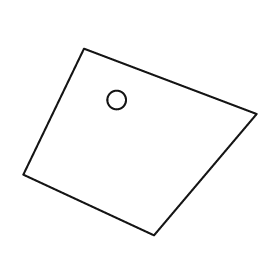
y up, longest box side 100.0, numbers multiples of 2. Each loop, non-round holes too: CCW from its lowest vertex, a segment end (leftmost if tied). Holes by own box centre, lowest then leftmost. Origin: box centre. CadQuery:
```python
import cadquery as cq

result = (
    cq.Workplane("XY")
    .moveTo(6.0, -40.0)
    .lineTo(50.0, 12.0)
    .lineTo(-24.0, 40.0)
    .lineTo(-50.0, -14.0)
    .close()
    .moveTo(-10.0, 18.0)
    .circle(4.0)
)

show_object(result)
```